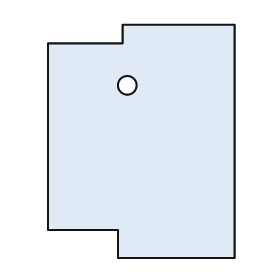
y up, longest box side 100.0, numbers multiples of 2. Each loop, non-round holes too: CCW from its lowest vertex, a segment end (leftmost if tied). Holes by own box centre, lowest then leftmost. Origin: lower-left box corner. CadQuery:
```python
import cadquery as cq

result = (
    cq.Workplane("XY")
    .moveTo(30.0, 0.0)
    .lineTo(80.0, 0.0)
    .lineTo(80.0, 100.0)
    .lineTo(32.0, 100.0)
    .lineTo(32.0, 92.0)
    .lineTo(0.0, 92.0)
    .lineTo(0.0, 12.0)
    .lineTo(30.0, 12.0)
    .close()
    .moveTo(34.0, 74.0)
    .circle(4.0)
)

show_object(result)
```